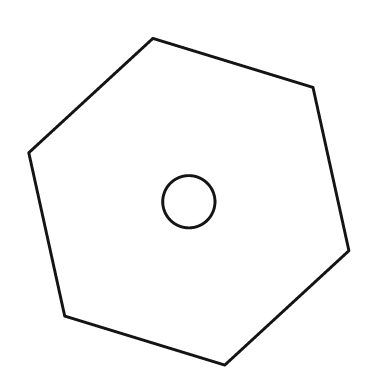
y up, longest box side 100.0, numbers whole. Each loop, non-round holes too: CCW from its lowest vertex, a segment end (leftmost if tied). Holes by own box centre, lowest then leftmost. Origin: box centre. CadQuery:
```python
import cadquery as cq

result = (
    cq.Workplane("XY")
    .moveTo(11.0, -50.0)
    .lineTo(49.0, -15.0)
    .lineTo(38.0, 35.0)
    .lineTo(-11.0, 50.0)
    .lineTo(-49.0, 15.0)
    .lineTo(-38.0, -35.0)
    .close()
    .moveTo(0.0, 0.0)
    .circle(8.0)
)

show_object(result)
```